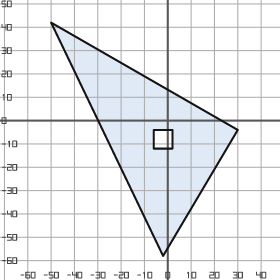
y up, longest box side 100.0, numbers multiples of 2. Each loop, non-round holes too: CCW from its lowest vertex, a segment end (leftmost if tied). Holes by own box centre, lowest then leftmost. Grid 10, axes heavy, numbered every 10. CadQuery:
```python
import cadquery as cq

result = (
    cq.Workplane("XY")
    .moveTo(-2.0, -58.0)
    .lineTo(30.0, -4.0)
    .lineTo(-50.0, 42.0)
    .close()
    .moveTo(-6.0, -12.0)
    .lineTo(2.0, -12.0)
    .lineTo(2.0, -4.0)
    .lineTo(-6.0, -4.0)
    .close()
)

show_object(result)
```